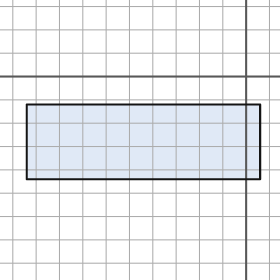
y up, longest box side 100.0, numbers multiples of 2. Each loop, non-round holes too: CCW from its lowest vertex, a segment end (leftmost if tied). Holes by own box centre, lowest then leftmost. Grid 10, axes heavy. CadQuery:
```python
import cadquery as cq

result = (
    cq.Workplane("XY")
    .moveTo(-94.0, -44.0)
    .lineTo(6.0, -44.0)
    .lineTo(6.0, -12.0)
    .lineTo(-94.0, -12.0)
    .close()
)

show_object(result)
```